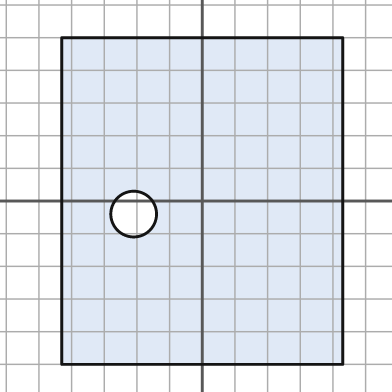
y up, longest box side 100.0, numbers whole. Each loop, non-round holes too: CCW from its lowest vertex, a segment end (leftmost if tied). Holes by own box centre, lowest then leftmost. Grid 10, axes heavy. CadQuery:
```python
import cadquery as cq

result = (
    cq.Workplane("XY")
    .moveTo(-43.0, -50.0)
    .lineTo(43.0, -50.0)
    .lineTo(43.0, 50.0)
    .lineTo(-43.0, 50.0)
    .close()
    .moveTo(-21.0, -4.0)
    .circle(7.0)
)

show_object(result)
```